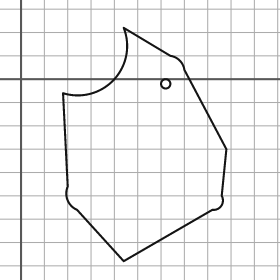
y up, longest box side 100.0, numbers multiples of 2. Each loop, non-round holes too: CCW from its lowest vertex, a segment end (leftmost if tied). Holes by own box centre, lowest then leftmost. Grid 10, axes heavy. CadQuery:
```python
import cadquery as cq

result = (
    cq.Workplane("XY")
    .moveTo(44.0, -78.0)
    .lineTo(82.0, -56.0)
    .threePointArc((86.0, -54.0), (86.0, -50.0))
    .lineTo(88.0, -30.0)
    .lineTo(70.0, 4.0)
    .threePointArc((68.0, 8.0), (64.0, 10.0))
    .lineTo(44.0, 22.0)
    .threePointArc((40.0, 0.0), (18.0, -6.0))
    .lineTo(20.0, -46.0)
    .threePointArc((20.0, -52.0), (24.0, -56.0))
    .close()
    .moveTo(62.0, -2.0)
    .circle(2.0)
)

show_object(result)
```